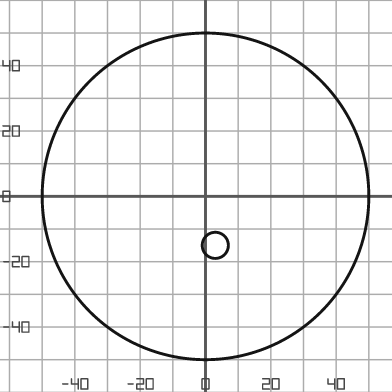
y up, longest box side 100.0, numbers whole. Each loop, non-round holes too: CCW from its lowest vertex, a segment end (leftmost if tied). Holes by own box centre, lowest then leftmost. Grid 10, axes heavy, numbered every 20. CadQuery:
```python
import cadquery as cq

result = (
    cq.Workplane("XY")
    .moveTo(0.0, 0.0)
    .circle(50.0)
    .moveTo(3.0, -15.0)
    .circle(4.0)
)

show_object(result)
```